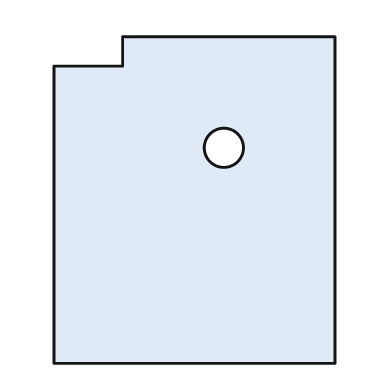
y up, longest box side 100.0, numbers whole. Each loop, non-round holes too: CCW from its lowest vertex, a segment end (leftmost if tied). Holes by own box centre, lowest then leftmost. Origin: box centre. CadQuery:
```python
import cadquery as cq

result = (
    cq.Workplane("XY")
    .moveTo(-43.0, -50.0)
    .lineTo(43.0, -50.0)
    .lineTo(43.0, 50.0)
    .lineTo(-22.0, 50.0)
    .lineTo(-22.0, 41.0)
    .lineTo(-43.0, 41.0)
    .close()
    .moveTo(9.0, 16.0)
    .circle(6.0)
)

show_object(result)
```